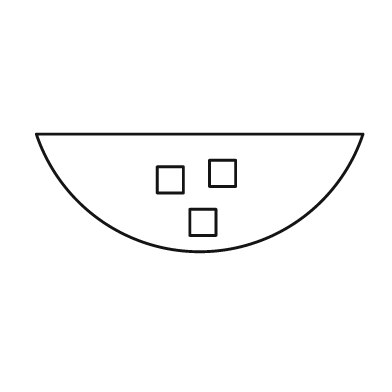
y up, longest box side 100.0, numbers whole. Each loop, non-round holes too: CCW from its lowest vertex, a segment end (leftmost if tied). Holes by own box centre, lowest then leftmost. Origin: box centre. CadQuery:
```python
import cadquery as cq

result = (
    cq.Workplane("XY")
    .moveTo(-50.0, 18.0)
    .threePointArc((0.0, -18.0), (50.0, 18.0))
    .close()
    .moveTo(-3.0, -13.0)
    .lineTo(5.0, -13.0)
    .lineTo(5.0, -5.0)
    .lineTo(-3.0, -5.0)
    .close()
    .moveTo(-13.0, 0.0)
    .lineTo(-5.0, 0.0)
    .lineTo(-5.0, 8.0)
    .lineTo(-13.0, 8.0)
    .close()
    .moveTo(3.0, 2.0)
    .lineTo(11.0, 2.0)
    .lineTo(11.0, 10.0)
    .lineTo(3.0, 10.0)
    .close()
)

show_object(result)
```